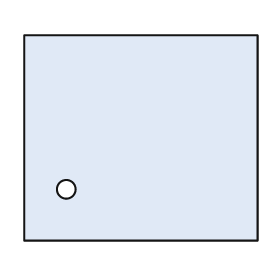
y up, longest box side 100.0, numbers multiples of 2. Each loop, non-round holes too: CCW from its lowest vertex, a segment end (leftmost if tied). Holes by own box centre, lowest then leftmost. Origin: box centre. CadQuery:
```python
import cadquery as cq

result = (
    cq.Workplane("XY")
    .moveTo(-50.0, -44.0)
    .lineTo(50.0, -44.0)
    .lineTo(50.0, 44.0)
    .lineTo(-50.0, 44.0)
    .close()
    .moveTo(-32.0, -22.0)
    .circle(4.0)
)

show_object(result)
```